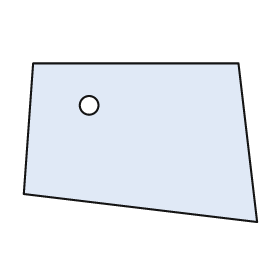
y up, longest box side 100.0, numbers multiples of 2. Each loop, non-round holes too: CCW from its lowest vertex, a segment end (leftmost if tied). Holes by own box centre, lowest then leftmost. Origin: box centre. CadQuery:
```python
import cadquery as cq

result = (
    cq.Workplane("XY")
    .moveTo(50.0, -34.0)
    .lineTo(42.0, 34.0)
    .lineTo(-46.0, 34.0)
    .lineTo(-50.0, -22.0)
    .close()
    .moveTo(-22.0, 16.0)
    .circle(4.0)
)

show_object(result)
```